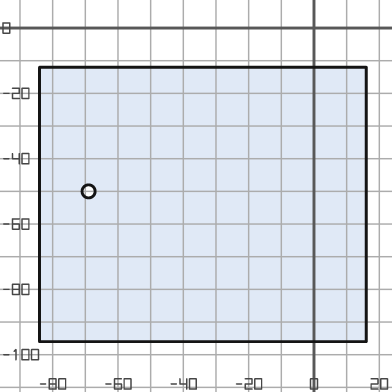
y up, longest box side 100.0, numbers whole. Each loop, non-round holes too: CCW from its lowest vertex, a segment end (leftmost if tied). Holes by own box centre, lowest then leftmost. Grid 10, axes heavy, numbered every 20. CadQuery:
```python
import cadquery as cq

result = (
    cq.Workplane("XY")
    .moveTo(-84.0, -96.0)
    .lineTo(16.0, -96.0)
    .lineTo(16.0, -12.0)
    .lineTo(-84.0, -12.0)
    .close()
    .moveTo(-69.0, -50.0)
    .circle(2.0)
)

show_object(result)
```